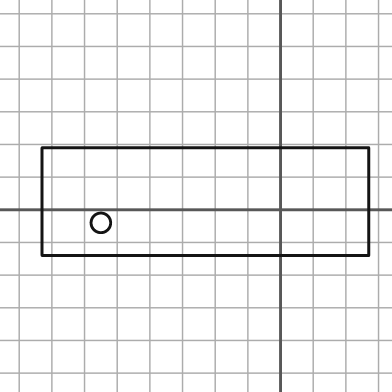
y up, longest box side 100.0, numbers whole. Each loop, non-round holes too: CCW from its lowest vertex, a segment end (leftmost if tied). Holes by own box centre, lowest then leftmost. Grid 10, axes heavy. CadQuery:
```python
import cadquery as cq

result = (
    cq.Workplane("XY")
    .moveTo(-73.0, -14.0)
    .lineTo(27.0, -14.0)
    .lineTo(27.0, 19.0)
    .lineTo(-73.0, 19.0)
    .close()
    .moveTo(-55.0, -4.0)
    .circle(3.0)
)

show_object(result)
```